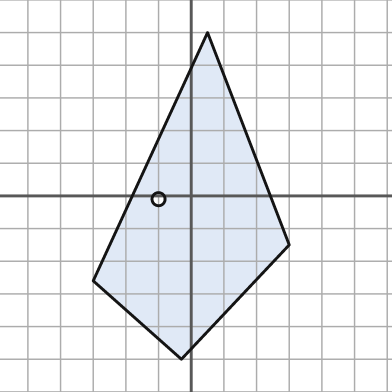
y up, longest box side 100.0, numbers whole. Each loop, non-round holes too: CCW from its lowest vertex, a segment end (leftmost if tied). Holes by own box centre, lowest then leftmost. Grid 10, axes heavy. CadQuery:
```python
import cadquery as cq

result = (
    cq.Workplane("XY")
    .moveTo(-3.0, -50.0)
    .lineTo(30.0, -15.0)
    .lineTo(5.0, 50.0)
    .lineTo(-30.0, -26.0)
    .close()
    .moveTo(-10.0, -1.0)
    .circle(2.0)
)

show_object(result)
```